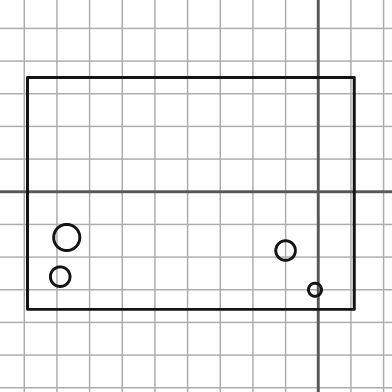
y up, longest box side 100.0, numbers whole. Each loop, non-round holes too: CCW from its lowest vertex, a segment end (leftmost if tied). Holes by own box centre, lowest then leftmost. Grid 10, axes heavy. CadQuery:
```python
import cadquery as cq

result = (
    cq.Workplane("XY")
    .moveTo(-89.0, -36.0)
    .lineTo(11.0, -36.0)
    .lineTo(11.0, 35.0)
    .lineTo(-89.0, 35.0)
    .close()
    .moveTo(-1.0, -30.0)
    .circle(2.0)
    .moveTo(-79.0, -26.0)
    .circle(3.0)
    .moveTo(-10.0, -18.0)
    .circle(3.0)
    .moveTo(-77.0, -14.0)
    .circle(4.0)
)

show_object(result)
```